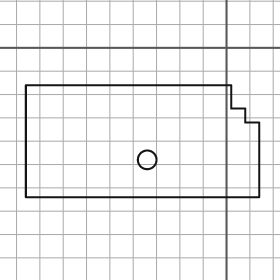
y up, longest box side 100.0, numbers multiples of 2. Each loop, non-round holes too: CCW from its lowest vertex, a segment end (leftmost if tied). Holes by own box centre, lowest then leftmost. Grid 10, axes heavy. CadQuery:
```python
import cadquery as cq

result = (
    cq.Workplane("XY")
    .moveTo(-86.0, -64.0)
    .lineTo(14.0, -64.0)
    .lineTo(14.0, -32.0)
    .lineTo(8.0, -32.0)
    .lineTo(8.0, -26.0)
    .lineTo(2.0, -26.0)
    .lineTo(2.0, -16.0)
    .lineTo(-86.0, -16.0)
    .close()
    .moveTo(-34.0, -48.0)
    .circle(4.0)
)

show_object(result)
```